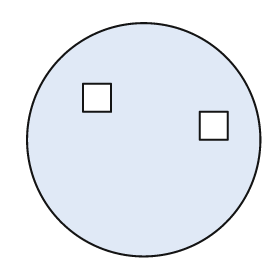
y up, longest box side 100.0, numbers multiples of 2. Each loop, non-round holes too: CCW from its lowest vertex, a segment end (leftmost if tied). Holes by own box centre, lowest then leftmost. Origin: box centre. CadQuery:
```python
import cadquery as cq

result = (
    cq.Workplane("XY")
    .moveTo(0.0, 0.0)
    .circle(50.0)
    .moveTo(24.0, 0.0)
    .lineTo(36.0, 0.0)
    .lineTo(36.0, 12.0)
    .lineTo(24.0, 12.0)
    .close()
    .moveTo(-26.0, 12.0)
    .lineTo(-14.0, 12.0)
    .lineTo(-14.0, 24.0)
    .lineTo(-26.0, 24.0)
    .close()
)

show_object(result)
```